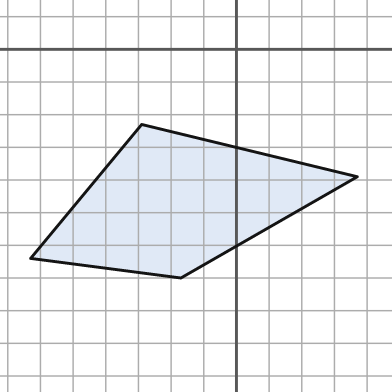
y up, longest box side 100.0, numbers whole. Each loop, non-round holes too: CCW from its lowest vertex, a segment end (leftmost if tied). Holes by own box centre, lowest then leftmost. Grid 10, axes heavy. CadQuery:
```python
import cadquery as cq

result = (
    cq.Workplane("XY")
    .moveTo(-17.0, -70.0)
    .lineTo(37.0, -39.0)
    .lineTo(-29.0, -23.0)
    .lineTo(-63.0, -64.0)
    .close()
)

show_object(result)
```